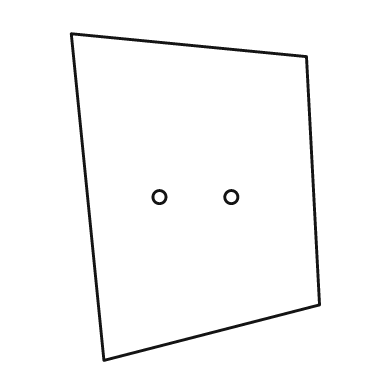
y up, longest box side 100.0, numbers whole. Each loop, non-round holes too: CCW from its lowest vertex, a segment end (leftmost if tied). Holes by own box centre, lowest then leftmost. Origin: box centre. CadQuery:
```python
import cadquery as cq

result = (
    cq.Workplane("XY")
    .moveTo(-28.0, -50.0)
    .lineTo(38.0, -33.0)
    .lineTo(34.0, 43.0)
    .lineTo(-38.0, 50.0)
    .close()
    .moveTo(-11.0, 0.0)
    .circle(2.0)
    .moveTo(11.0, 0.0)
    .circle(2.0)
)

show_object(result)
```